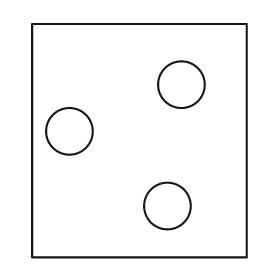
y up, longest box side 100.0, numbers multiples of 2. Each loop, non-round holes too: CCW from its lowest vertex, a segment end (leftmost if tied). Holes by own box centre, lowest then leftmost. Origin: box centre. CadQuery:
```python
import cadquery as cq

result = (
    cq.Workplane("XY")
    .moveTo(-46.0, -50.0)
    .lineTo(46.0, -50.0)
    .lineTo(46.0, 50.0)
    .lineTo(-46.0, 50.0)
    .close()
    .moveTo(12.0, -28.0)
    .circle(10.0)
    .moveTo(-30.0, 4.0)
    .circle(10.0)
    .moveTo(18.0, 24.0)
    .circle(10.0)
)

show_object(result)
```